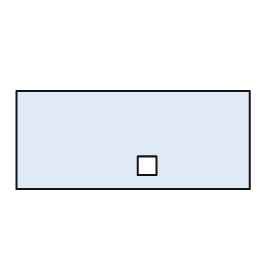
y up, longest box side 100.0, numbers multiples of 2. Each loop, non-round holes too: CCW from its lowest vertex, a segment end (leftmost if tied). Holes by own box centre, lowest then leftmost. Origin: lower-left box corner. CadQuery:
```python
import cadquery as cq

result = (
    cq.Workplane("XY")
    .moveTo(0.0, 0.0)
    .lineTo(100.0, 0.0)
    .lineTo(100.0, 42.0)
    .lineTo(0.0, 42.0)
    .close()
    .moveTo(52.0, 6.0)
    .lineTo(60.0, 6.0)
    .lineTo(60.0, 14.0)
    .lineTo(52.0, 14.0)
    .close()
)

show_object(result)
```